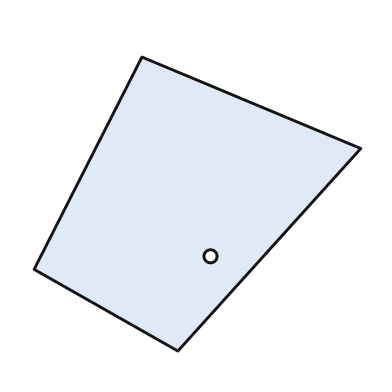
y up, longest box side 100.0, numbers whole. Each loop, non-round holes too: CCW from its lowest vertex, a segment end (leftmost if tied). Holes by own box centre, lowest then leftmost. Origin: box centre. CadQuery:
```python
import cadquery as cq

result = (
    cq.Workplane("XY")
    .moveTo(-6.0, -45.0)
    .lineTo(50.0, 17.0)
    .lineTo(-17.0, 45.0)
    .lineTo(-50.0, -20.0)
    .close()
    .moveTo(4.0, -16.0)
    .circle(2.0)
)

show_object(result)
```